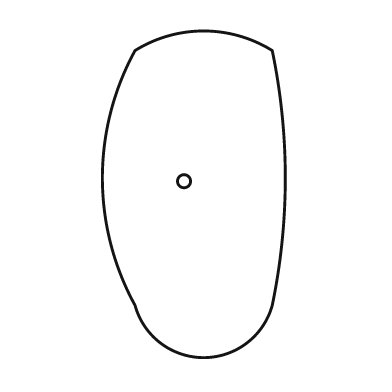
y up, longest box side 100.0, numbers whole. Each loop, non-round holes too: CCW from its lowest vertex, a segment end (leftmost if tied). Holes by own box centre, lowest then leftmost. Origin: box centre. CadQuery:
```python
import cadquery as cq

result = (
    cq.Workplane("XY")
    .moveTo(-18.0, -34.0)
    .threePointArc((3.0, -50.0), (24.0, -34.0))
    .threePointArc((28.0, 5.0), (24.0, 44.0))
    .threePointArc((3.0, 50.0), (-18.0, 44.0))
    .threePointArc((-28.0, 5.0), (-18.0, -34.0))
    .close()
    .moveTo(-3.0, 4.0)
    .circle(2.0)
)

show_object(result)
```